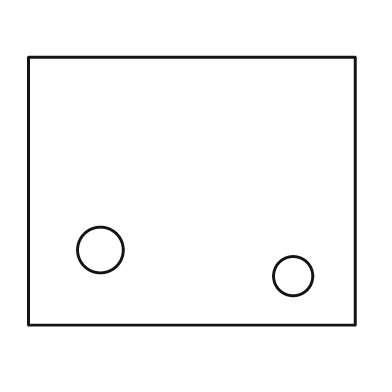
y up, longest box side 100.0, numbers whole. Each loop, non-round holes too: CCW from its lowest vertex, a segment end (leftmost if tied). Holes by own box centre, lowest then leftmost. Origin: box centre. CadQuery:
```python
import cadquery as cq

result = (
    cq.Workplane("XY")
    .moveTo(-50.0, -41.0)
    .lineTo(50.0, -41.0)
    .lineTo(50.0, 41.0)
    .lineTo(-50.0, 41.0)
    .close()
    .moveTo(31.0, -26.0)
    .circle(6.0)
    .moveTo(-28.0, -18.0)
    .circle(7.0)
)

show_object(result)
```